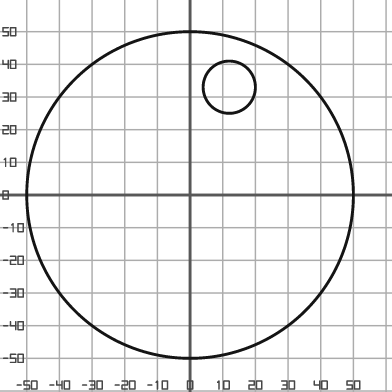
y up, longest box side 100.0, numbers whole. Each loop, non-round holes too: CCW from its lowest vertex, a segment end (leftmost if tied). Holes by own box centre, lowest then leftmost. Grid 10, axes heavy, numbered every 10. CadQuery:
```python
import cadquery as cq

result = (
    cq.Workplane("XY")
    .moveTo(0.0, 0.0)
    .circle(50.0)
    .moveTo(12.0, 33.0)
    .circle(8.0)
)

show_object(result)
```